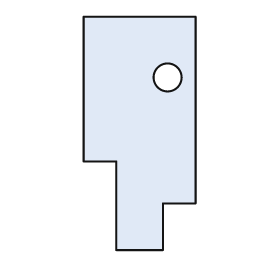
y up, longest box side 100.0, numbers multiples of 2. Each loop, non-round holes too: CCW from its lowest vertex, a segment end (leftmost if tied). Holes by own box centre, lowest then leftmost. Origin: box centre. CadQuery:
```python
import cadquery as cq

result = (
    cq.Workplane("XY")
    .moveTo(-10.0, -50.0)
    .lineTo(10.0, -50.0)
    .lineTo(10.0, -30.0)
    .lineTo(24.0, -30.0)
    .lineTo(24.0, 50.0)
    .lineTo(-24.0, 50.0)
    .lineTo(-24.0, -12.0)
    .lineTo(-10.0, -12.0)
    .close()
    .moveTo(12.0, 24.0)
    .circle(6.0)
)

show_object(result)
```